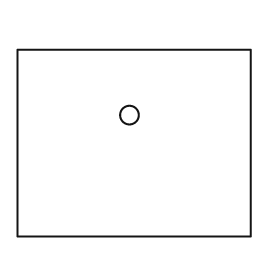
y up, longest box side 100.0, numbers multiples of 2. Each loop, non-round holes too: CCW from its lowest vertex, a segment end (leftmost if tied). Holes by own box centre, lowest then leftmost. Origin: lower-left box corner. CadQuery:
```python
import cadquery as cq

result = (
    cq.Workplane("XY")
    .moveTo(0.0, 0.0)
    .lineTo(100.0, 0.0)
    .lineTo(100.0, 80.0)
    .lineTo(0.0, 80.0)
    .close()
    .moveTo(48.0, 52.0)
    .circle(4.0)
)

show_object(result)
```